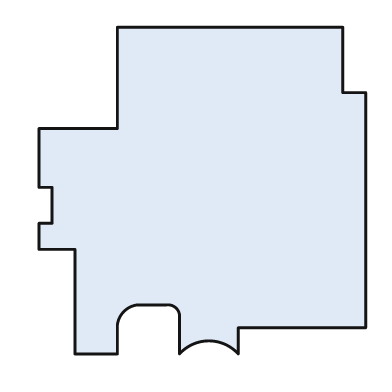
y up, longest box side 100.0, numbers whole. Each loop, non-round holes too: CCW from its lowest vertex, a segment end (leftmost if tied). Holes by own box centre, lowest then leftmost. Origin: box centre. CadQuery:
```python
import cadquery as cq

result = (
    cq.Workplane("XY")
    .moveTo(-39.0, -50.0)
    .lineTo(-26.0, -50.0)
    .lineTo(-26.0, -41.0)
    .threePointArc((-24.0, -37.0), (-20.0, -35.0))
    .lineTo(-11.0, -35.0)
    .threePointArc((-8.0, -36.0), (-7.0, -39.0))
    .lineTo(-7.0, -50.0)
    .threePointArc((2.0, -46.0), (11.0, -50.0))
    .lineTo(11.0, -42.0)
    .lineTo(50.0, -42.0)
    .lineTo(50.0, 30.0)
    .lineTo(43.0, 30.0)
    .lineTo(43.0, 50.0)
    .lineTo(-26.0, 50.0)
    .lineTo(-26.0, 19.0)
    .lineTo(-50.0, 19.0)
    .lineTo(-50.0, 1.0)
    .lineTo(-46.0, 1.0)
    .lineTo(-46.0, -10.0)
    .lineTo(-50.0, -10.0)
    .lineTo(-50.0, -18.0)
    .lineTo(-39.0, -18.0)
    .close()
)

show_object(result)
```